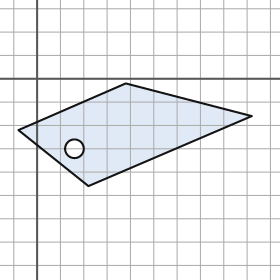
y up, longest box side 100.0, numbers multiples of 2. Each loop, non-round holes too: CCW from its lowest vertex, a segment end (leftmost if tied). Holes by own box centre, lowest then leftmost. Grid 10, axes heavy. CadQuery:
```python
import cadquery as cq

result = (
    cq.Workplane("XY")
    .moveTo(22.0, -46.0)
    .lineTo(92.0, -16.0)
    .lineTo(38.0, -2.0)
    .lineTo(-8.0, -22.0)
    .close()
    .moveTo(16.0, -30.0)
    .circle(4.0)
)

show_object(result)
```